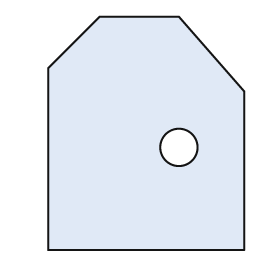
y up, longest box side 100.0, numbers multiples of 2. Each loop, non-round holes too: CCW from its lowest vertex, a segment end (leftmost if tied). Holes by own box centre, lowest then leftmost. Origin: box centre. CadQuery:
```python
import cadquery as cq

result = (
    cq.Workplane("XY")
    .moveTo(-42.0, -50.0)
    .lineTo(42.0, -50.0)
    .lineTo(42.0, 18.0)
    .lineTo(14.0, 50.0)
    .lineTo(-20.0, 50.0)
    .lineTo(-42.0, 28.0)
    .close()
    .moveTo(14.0, -6.0)
    .circle(8.0)
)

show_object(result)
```